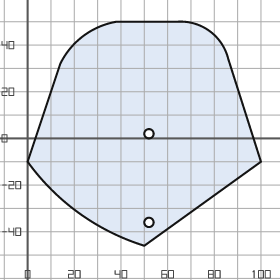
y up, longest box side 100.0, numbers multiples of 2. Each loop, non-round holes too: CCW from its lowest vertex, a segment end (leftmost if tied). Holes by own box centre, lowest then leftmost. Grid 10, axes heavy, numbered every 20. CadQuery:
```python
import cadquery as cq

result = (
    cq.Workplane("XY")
    .moveTo(50.0, -46.0)
    .lineTo(100.0, -10.0)
    .lineTo(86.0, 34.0)
    .threePointArc((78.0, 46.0), (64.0, 50.0))
    .lineTo(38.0, 50.0)
    .threePointArc((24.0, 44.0), (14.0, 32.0))
    .lineTo(0.0, -10.0)
    .threePointArc((22.0, -32.0), (50.0, -46.0))
    .close()
    .moveTo(52.0, -36.0)
    .circle(2.0)
    .moveTo(52.0, 2.0)
    .circle(2.0)
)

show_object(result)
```